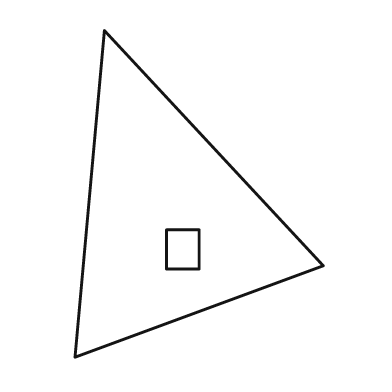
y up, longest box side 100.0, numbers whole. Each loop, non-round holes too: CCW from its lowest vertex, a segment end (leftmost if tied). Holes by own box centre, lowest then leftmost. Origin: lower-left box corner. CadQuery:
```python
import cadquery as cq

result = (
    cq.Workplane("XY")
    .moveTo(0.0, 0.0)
    .lineTo(76.0, 28.0)
    .lineTo(9.0, 100.0)
    .close()
    .moveTo(28.0, 27.0)
    .lineTo(38.0, 27.0)
    .lineTo(38.0, 39.0)
    .lineTo(28.0, 39.0)
    .close()
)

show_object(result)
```